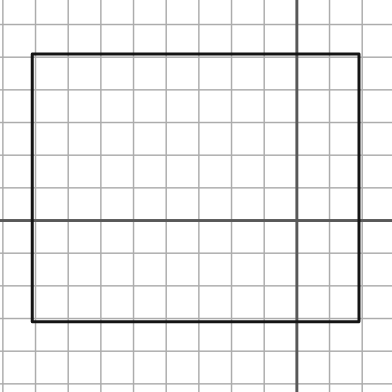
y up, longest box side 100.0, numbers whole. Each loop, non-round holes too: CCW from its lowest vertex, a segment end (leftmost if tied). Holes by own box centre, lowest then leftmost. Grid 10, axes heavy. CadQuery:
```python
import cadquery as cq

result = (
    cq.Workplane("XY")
    .moveTo(-81.0, -31.0)
    .lineTo(19.0, -31.0)
    .lineTo(19.0, 51.0)
    .lineTo(-81.0, 51.0)
    .close()
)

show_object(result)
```